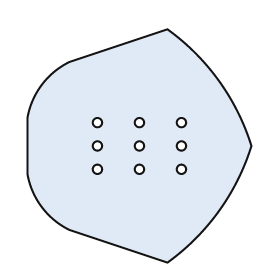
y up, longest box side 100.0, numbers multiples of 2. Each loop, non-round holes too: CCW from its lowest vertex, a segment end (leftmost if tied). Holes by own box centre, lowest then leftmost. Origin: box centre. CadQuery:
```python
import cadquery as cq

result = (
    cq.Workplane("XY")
    .moveTo(12.0, -50.0)
    .threePointArc((34.0, -28.0), (48.0, 0.0))
    .threePointArc((34.0, 28.0), (12.0, 50.0))
    .lineTo(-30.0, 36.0)
    .threePointArc((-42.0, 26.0), (-48.0, 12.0))
    .lineTo(-48.0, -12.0)
    .threePointArc((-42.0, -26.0), (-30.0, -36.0))
    .close()
    .moveTo(-18.0, -10.0)
    .circle(2.0)
    .moveTo(0.0, -10.0)
    .circle(2.0)
    .moveTo(18.0, -10.0)
    .circle(2.0)
    .moveTo(-18.0, 0.0)
    .circle(2.0)
    .moveTo(0.0, 0.0)
    .circle(2.0)
    .moveTo(18.0, 0.0)
    .circle(2.0)
    .moveTo(-18.0, 10.0)
    .circle(2.0)
    .moveTo(0.0, 10.0)
    .circle(2.0)
    .moveTo(18.0, 10.0)
    .circle(2.0)
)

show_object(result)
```